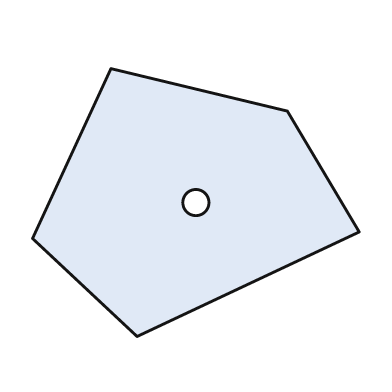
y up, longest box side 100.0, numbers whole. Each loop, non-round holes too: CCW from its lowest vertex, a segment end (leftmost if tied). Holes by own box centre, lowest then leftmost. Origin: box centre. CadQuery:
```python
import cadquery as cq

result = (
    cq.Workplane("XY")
    .moveTo(-18.0, -41.0)
    .lineTo(50.0, -9.0)
    .lineTo(28.0, 28.0)
    .lineTo(-26.0, 41.0)
    .lineTo(-50.0, -11.0)
    .close()
    .moveTo(0.0, 0.0)
    .circle(4.0)
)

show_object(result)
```